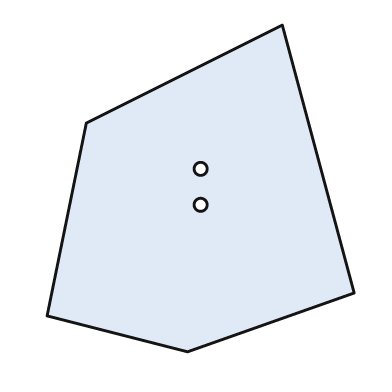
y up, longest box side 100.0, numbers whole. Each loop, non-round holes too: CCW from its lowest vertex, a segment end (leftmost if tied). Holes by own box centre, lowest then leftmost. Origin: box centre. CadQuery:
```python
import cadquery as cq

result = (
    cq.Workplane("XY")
    .moveTo(-4.0, -50.0)
    .lineTo(47.0, -32.0)
    .lineTo(25.0, 50.0)
    .lineTo(-35.0, 20.0)
    .lineTo(-47.0, -39.0)
    .close()
    .moveTo(0.0, -5.0)
    .circle(2.0)
    .moveTo(0.0, 6.0)
    .circle(2.0)
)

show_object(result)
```